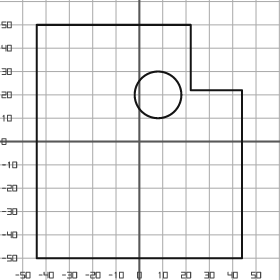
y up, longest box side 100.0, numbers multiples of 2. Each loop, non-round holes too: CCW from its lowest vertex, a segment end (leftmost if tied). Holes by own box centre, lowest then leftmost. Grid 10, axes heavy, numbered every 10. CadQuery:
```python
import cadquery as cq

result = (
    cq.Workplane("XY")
    .moveTo(-44.0, -50.0)
    .lineTo(44.0, -50.0)
    .lineTo(44.0, 22.0)
    .lineTo(22.0, 22.0)
    .lineTo(22.0, 50.0)
    .lineTo(-44.0, 50.0)
    .close()
    .moveTo(8.0, 20.0)
    .circle(10.0)
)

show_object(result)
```